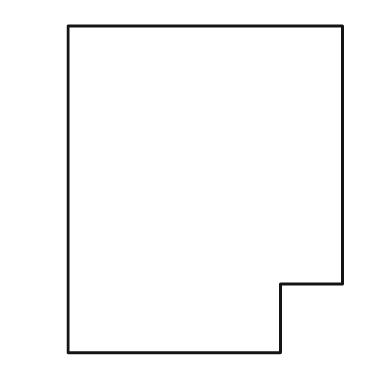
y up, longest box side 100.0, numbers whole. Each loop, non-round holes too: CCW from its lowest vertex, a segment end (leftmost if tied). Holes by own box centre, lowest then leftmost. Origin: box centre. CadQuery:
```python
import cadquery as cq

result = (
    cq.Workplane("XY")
    .moveTo(-42.0, -50.0)
    .lineTo(23.0, -50.0)
    .lineTo(23.0, -29.0)
    .lineTo(42.0, -29.0)
    .lineTo(42.0, 50.0)
    .lineTo(-42.0, 50.0)
    .close()
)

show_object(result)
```